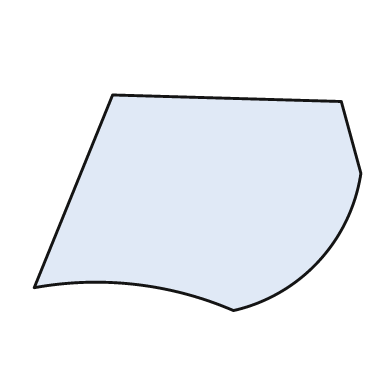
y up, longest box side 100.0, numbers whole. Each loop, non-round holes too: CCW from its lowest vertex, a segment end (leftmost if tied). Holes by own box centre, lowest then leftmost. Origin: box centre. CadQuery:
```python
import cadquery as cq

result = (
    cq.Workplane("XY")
    .moveTo(11.0, -33.0)
    .threePointArc((37.0, -18.0), (50.0, 9.0))
    .lineTo(44.0, 31.0)
    .lineTo(-26.0, 33.0)
    .lineTo(-50.0, -26.0)
    .threePointArc((-19.0, -25.0), (11.0, -33.0))
    .close()
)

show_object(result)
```